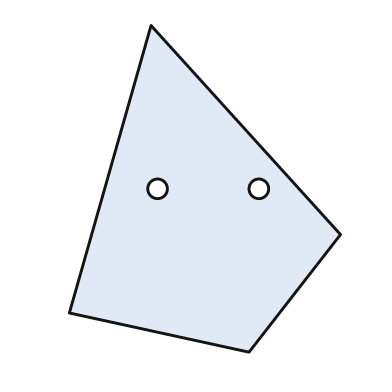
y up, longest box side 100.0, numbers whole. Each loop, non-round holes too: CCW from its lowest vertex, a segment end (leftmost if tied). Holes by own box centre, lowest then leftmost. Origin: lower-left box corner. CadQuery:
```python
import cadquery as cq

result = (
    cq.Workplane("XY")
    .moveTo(55.0, 0.0)
    .lineTo(83.0, 36.0)
    .lineTo(25.0, 100.0)
    .lineTo(0.0, 12.0)
    .close()
    .moveTo(27.0, 50.0)
    .circle(3.0)
    .moveTo(58.0, 50.0)
    .circle(3.0)
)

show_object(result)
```